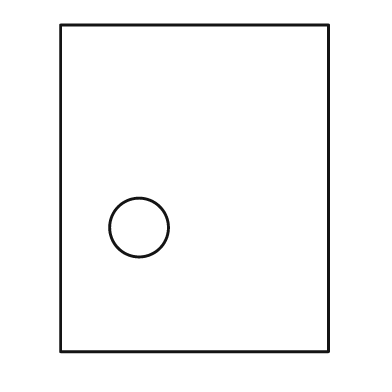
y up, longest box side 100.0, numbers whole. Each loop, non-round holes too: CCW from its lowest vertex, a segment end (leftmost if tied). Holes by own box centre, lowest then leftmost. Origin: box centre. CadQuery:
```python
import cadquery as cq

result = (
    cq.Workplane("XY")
    .moveTo(-41.0, -50.0)
    .lineTo(41.0, -50.0)
    .lineTo(41.0, 50.0)
    .lineTo(-41.0, 50.0)
    .close()
    .moveTo(-17.0, -12.0)
    .circle(9.0)
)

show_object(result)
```